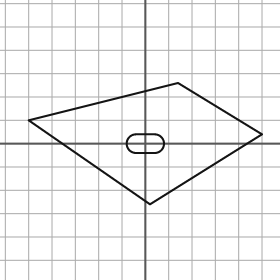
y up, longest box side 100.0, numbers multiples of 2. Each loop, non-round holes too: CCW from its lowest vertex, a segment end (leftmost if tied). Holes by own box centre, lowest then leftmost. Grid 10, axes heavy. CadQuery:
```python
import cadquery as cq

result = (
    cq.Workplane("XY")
    .moveTo(2.0, -26.0)
    .lineTo(50.0, 4.0)
    .lineTo(14.0, 26.0)
    .lineTo(-50.0, 10.0)
    .close()
    .moveTo(-4.0, -4.0)
    .lineTo(4.0, -4.0)
    .threePointArc((8.0, 0.0), (4.0, 4.0))
    .lineTo(-4.0, 4.0)
    .threePointArc((-8.0, 0.0), (-4.0, -4.0))
    .close()
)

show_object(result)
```